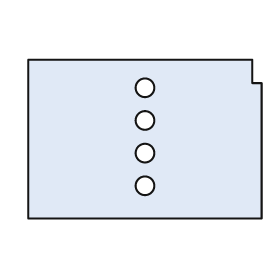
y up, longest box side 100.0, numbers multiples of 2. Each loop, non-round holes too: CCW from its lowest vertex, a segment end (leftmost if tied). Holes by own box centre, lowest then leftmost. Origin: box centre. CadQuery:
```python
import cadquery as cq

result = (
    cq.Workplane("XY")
    .moveTo(-50.0, -34.0)
    .lineTo(50.0, -34.0)
    .lineTo(50.0, 24.0)
    .lineTo(46.0, 24.0)
    .lineTo(46.0, 34.0)
    .lineTo(-50.0, 34.0)
    .close()
    .moveTo(0.0, -20.0)
    .circle(4.0)
    .moveTo(0.0, -6.0)
    .circle(4.0)
    .moveTo(0.0, 8.0)
    .circle(4.0)
    .moveTo(0.0, 22.0)
    .circle(4.0)
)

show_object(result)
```